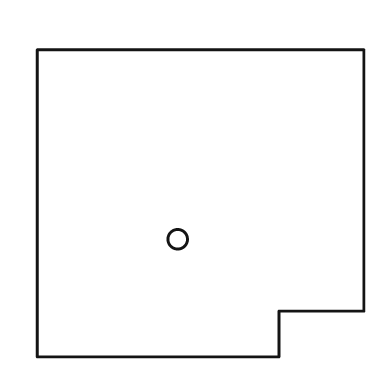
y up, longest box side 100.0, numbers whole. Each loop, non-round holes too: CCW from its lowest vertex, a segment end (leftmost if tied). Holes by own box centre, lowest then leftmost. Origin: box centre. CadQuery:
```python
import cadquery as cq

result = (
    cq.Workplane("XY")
    .moveTo(-50.0, -47.0)
    .lineTo(24.0, -47.0)
    .lineTo(24.0, -33.0)
    .lineTo(50.0, -33.0)
    .lineTo(50.0, 47.0)
    .lineTo(-50.0, 47.0)
    .close()
    .moveTo(-7.0, -11.0)
    .circle(3.0)
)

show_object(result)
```